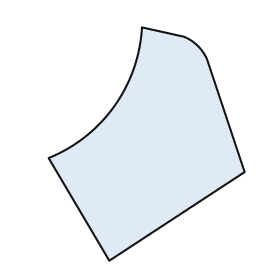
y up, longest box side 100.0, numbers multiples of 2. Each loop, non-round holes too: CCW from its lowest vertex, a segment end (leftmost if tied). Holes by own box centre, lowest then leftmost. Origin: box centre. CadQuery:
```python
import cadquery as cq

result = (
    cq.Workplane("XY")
    .moveTo(-16.0, -50.0)
    .lineTo(42.0, -12.0)
    .lineTo(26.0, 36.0)
    .threePointArc((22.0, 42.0), (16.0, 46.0))
    .lineTo(-2.0, 50.0)
    .threePointArc((-14.0, 16.0), (-42.0, -6.0))
    .close()
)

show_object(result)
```